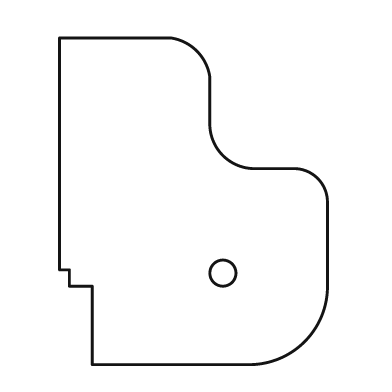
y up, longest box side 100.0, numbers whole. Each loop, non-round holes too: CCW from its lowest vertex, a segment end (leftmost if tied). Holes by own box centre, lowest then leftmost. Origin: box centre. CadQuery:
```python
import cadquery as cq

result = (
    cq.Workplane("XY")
    .moveTo(-31.0, -50.0)
    .lineTo(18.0, -50.0)
    .threePointArc((34.0, -43.0), (41.0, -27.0))
    .lineTo(41.0, 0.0)
    .threePointArc((38.0, 7.0), (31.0, 10.0))
    .lineTo(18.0, 10.0)
    .threePointArc((9.0, 14.0), (5.0, 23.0))
    .lineTo(5.0, 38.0)
    .threePointArc((1.0, 46.0), (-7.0, 50.0))
    .lineTo(-41.0, 50.0)
    .lineTo(-41.0, -21.0)
    .lineTo(-38.0, -21.0)
    .lineTo(-38.0, -26.0)
    .lineTo(-31.0, -26.0)
    .close()
    .moveTo(9.0, -22.0)
    .circle(4.0)
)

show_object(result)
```